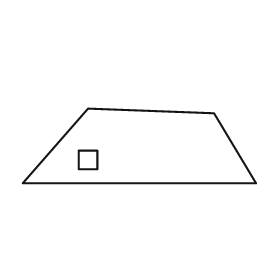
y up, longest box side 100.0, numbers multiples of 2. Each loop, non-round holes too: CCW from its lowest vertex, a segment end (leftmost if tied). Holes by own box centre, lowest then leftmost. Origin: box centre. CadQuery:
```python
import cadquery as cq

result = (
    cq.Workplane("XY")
    .moveTo(-50.0, -16.0)
    .lineTo(50.0, -16.0)
    .lineTo(32.0, 14.0)
    .lineTo(-22.0, 16.0)
    .close()
    .moveTo(-26.0, -10.0)
    .lineTo(-18.0, -10.0)
    .lineTo(-18.0, -2.0)
    .lineTo(-26.0, -2.0)
    .close()
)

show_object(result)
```